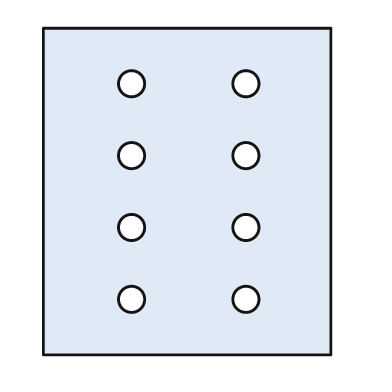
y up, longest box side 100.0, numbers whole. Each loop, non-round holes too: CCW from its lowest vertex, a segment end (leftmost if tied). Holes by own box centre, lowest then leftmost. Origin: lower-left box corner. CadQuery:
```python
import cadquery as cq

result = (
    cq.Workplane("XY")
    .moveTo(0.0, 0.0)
    .lineTo(88.0, 0.0)
    .lineTo(88.0, 100.0)
    .lineTo(0.0, 100.0)
    .close()
    .moveTo(27.0, 17.0)
    .circle(4.0)
    .moveTo(62.0, 17.0)
    .circle(4.0)
    .moveTo(27.0, 39.0)
    .circle(4.0)
    .moveTo(62.0, 39.0)
    .circle(4.0)
    .moveTo(27.0, 61.0)
    .circle(4.0)
    .moveTo(62.0, 61.0)
    .circle(4.0)
    .moveTo(27.0, 83.0)
    .circle(4.0)
    .moveTo(62.0, 83.0)
    .circle(4.0)
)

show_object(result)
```